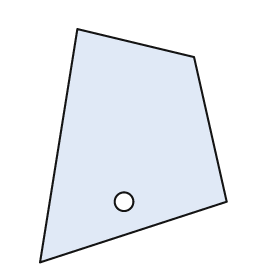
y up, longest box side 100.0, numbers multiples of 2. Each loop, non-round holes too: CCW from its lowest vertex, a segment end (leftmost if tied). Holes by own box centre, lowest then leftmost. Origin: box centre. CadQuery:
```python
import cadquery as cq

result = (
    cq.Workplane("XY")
    .moveTo(-40.0, -50.0)
    .lineTo(40.0, -24.0)
    .lineTo(26.0, 38.0)
    .lineTo(-24.0, 50.0)
    .close()
    .moveTo(-4.0, -24.0)
    .circle(4.0)
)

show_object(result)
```